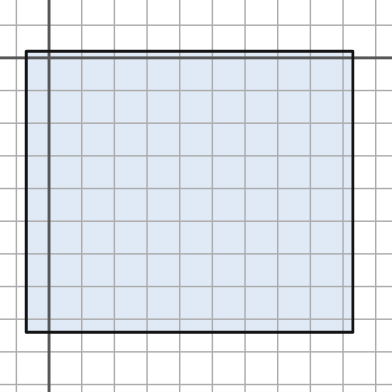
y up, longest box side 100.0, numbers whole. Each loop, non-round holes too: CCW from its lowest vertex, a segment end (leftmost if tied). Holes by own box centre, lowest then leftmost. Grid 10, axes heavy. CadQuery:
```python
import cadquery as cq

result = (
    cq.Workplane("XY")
    .moveTo(-7.0, -84.0)
    .lineTo(93.0, -84.0)
    .lineTo(93.0, 2.0)
    .lineTo(-7.0, 2.0)
    .close()
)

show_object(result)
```